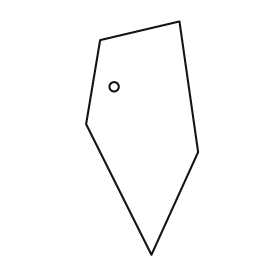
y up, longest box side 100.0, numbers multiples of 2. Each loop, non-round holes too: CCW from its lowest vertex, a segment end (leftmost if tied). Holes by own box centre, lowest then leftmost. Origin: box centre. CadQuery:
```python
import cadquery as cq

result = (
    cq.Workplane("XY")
    .moveTo(4.0, -50.0)
    .lineTo(24.0, -6.0)
    .lineTo(16.0, 50.0)
    .lineTo(-18.0, 42.0)
    .lineTo(-24.0, 6.0)
    .close()
    .moveTo(-12.0, 22.0)
    .circle(2.0)
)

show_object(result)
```